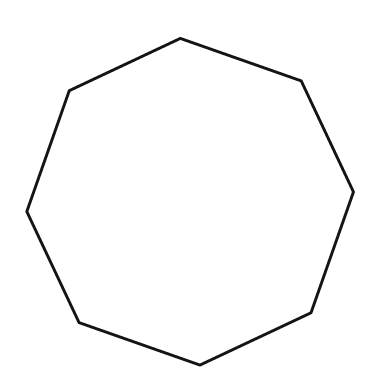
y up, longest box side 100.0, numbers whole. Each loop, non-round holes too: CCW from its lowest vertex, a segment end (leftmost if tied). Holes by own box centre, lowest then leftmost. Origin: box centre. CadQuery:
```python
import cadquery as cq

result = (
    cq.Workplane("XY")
    .moveTo(3.0, -50.0)
    .lineTo(37.0, -34.0)
    .lineTo(50.0, 3.0)
    .lineTo(34.0, 37.0)
    .lineTo(-3.0, 50.0)
    .lineTo(-37.0, 34.0)
    .lineTo(-50.0, -3.0)
    .lineTo(-34.0, -37.0)
    .close()
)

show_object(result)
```